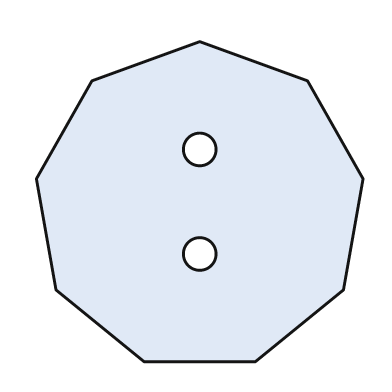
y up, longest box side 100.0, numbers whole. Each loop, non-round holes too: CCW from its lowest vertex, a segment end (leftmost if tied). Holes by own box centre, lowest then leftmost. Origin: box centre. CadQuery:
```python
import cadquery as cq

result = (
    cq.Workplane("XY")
    .moveTo(-17.0, -49.0)
    .lineTo(17.0, -49.0)
    .lineTo(44.0, -27.0)
    .lineTo(50.0, 7.0)
    .lineTo(33.0, 37.0)
    .lineTo(0.0, 49.0)
    .lineTo(-33.0, 37.0)
    .lineTo(-50.0, 7.0)
    .lineTo(-44.0, -27.0)
    .close()
    .moveTo(0.0, -16.0)
    .circle(5.0)
    .moveTo(0.0, 16.0)
    .circle(5.0)
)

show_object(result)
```